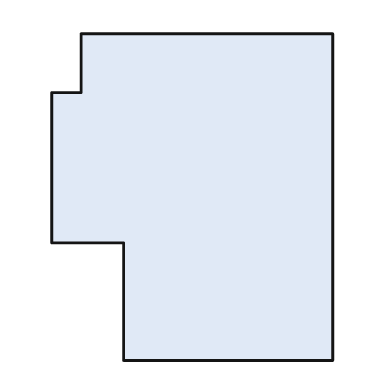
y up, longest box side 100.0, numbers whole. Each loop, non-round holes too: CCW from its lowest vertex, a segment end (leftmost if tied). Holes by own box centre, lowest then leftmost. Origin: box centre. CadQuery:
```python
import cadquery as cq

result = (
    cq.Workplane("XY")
    .moveTo(-21.0, -50.0)
    .lineTo(43.0, -50.0)
    .lineTo(43.0, 50.0)
    .lineTo(-34.0, 50.0)
    .lineTo(-34.0, 32.0)
    .lineTo(-43.0, 32.0)
    .lineTo(-43.0, -14.0)
    .lineTo(-21.0, -14.0)
    .close()
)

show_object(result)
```